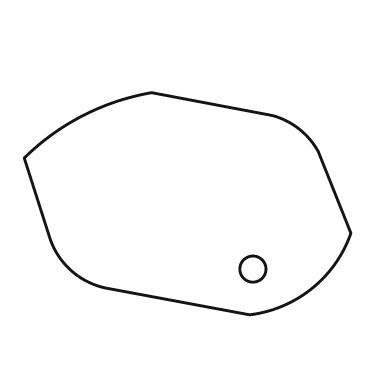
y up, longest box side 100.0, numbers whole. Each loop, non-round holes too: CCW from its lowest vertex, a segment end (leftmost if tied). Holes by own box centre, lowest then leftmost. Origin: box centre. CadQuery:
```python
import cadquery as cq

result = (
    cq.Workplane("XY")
    .moveTo(19.0, -34.0)
    .threePointArc((38.0, -26.0), (50.0, -9.0))
    .lineTo(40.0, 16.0)
    .threePointArc((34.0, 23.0), (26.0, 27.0))
    .lineTo(-11.0, 34.0)
    .threePointArc((-32.0, 27.0), (-50.0, 14.0))
    .lineTo(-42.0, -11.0)
    .threePointArc((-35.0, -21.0), (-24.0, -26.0))
    .close()
    .moveTo(20.0, -20.0)
    .circle(4.0)
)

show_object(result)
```